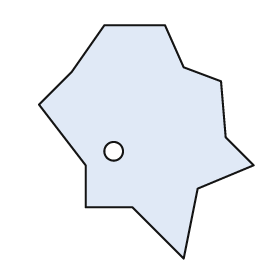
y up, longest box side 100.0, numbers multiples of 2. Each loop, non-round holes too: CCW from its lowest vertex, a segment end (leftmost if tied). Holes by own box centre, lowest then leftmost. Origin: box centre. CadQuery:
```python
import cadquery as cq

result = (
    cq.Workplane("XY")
    .moveTo(16.0, -50.0)
    .lineTo(22.0, -20.0)
    .lineTo(46.0, -10.0)
    .lineTo(34.0, 2.0)
    .lineTo(32.0, 26.0)
    .lineTo(16.0, 32.0)
    .lineTo(8.0, 50.0)
    .lineTo(-18.0, 50.0)
    .lineTo(-32.0, 30.0)
    .lineTo(-46.0, 16.0)
    .lineTo(-26.0, -10.0)
    .lineTo(-26.0, -28.0)
    .lineTo(-6.0, -28.0)
    .close()
    .moveTo(-14.0, -4.0)
    .circle(4.0)
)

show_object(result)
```